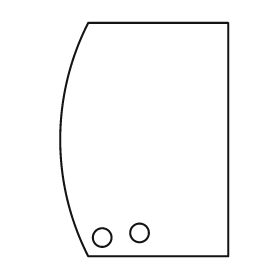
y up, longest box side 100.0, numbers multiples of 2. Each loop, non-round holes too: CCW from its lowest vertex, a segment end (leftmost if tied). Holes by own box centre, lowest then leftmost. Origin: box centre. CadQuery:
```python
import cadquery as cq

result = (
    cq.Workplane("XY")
    .moveTo(-24.0, -50.0)
    .lineTo(36.0, -50.0)
    .lineTo(36.0, 50.0)
    .lineTo(-24.0, 50.0)
    .threePointArc((-36.0, 0.0), (-24.0, -50.0))
    .close()
    .moveTo(-18.0, -42.0)
    .circle(4.0)
    .moveTo(-2.0, -40.0)
    .circle(4.0)
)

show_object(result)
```